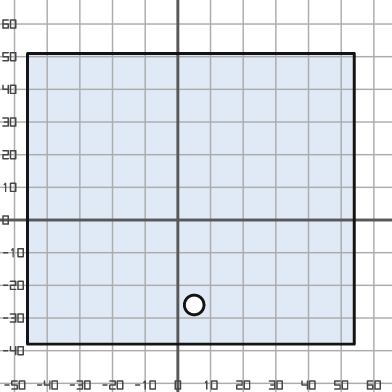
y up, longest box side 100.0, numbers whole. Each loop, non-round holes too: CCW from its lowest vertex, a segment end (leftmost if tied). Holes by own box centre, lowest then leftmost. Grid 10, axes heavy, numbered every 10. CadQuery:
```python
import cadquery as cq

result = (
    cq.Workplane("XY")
    .moveTo(-46.0, -38.0)
    .lineTo(54.0, -38.0)
    .lineTo(54.0, 51.0)
    .lineTo(-46.0, 51.0)
    .close()
    .moveTo(5.0, -26.0)
    .circle(3.0)
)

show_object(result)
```